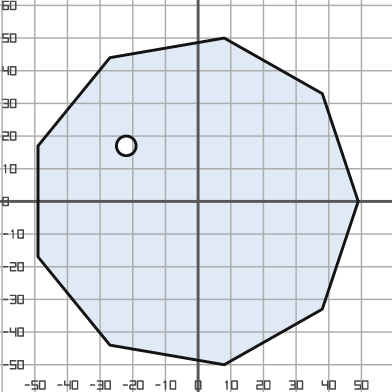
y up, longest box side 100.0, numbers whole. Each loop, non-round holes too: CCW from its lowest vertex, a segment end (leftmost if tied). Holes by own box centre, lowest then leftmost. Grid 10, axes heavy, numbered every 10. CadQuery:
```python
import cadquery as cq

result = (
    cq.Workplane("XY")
    .moveTo(8.0, -50.0)
    .lineTo(38.0, -33.0)
    .lineTo(49.0, 0.0)
    .lineTo(38.0, 33.0)
    .lineTo(8.0, 50.0)
    .lineTo(-27.0, 44.0)
    .lineTo(-49.0, 17.0)
    .lineTo(-49.0, -17.0)
    .lineTo(-27.0, -44.0)
    .close()
    .moveTo(-22.0, 17.0)
    .circle(3.0)
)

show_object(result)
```